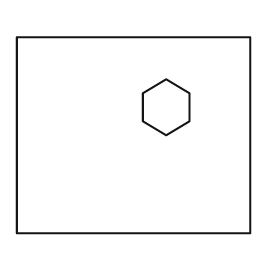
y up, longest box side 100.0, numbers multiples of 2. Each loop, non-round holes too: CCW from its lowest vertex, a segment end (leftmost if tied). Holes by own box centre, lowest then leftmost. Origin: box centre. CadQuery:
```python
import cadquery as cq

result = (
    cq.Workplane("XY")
    .moveTo(-50.0, -42.0)
    .lineTo(50.0, -42.0)
    .lineTo(50.0, 42.0)
    .lineTo(-50.0, 42.0)
    .close()
    .moveTo(14.0, 0.0)
    .lineTo(24.0, 6.0)
    .lineTo(24.0, 18.0)
    .lineTo(14.0, 24.0)
    .lineTo(4.0, 18.0)
    .lineTo(4.0, 6.0)
    .close()
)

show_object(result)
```